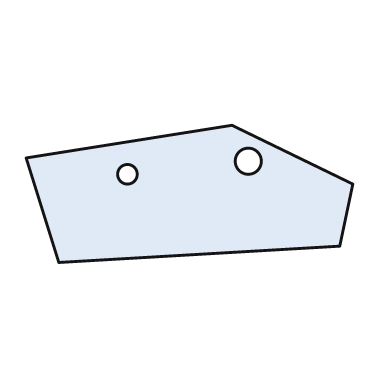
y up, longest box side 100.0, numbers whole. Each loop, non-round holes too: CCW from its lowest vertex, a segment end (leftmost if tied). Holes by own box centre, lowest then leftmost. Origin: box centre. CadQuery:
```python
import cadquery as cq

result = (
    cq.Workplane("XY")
    .moveTo(-40.0, -21.0)
    .lineTo(46.0, -16.0)
    .lineTo(50.0, 3.0)
    .lineTo(13.0, 21.0)
    .lineTo(-50.0, 11.0)
    .close()
    .moveTo(-19.0, 6.0)
    .circle(3.0)
    .moveTo(18.0, 10.0)
    .circle(4.0)
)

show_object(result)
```